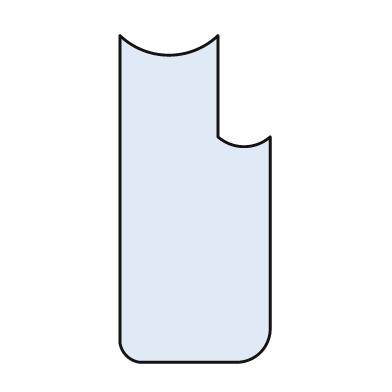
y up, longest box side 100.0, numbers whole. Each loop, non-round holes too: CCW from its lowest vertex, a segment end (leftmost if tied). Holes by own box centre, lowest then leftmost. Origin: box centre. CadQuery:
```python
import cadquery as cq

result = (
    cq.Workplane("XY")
    .moveTo(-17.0, -50.0)
    .lineTo(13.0, -50.0)
    .threePointArc((20.0, -47.0), (23.0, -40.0))
    .lineTo(23.0, 19.0)
    .threePointArc((15.0, 16.0), (7.0, 19.0))
    .lineTo(7.0, 50.0)
    .threePointArc((-8.0, 44.0), (-23.0, 50.0))
    .lineTo(-23.0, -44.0)
    .threePointArc((-21.0, -48.0), (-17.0, -50.0))
    .close()
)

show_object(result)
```